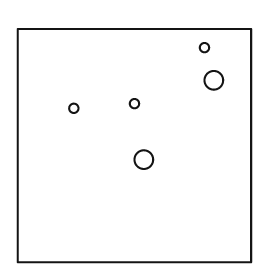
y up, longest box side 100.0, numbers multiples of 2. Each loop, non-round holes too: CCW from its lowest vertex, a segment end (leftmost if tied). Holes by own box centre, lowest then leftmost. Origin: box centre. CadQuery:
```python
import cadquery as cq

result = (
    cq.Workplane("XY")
    .moveTo(-50.0, -50.0)
    .lineTo(50.0, -50.0)
    .lineTo(50.0, 50.0)
    .lineTo(-50.0, 50.0)
    .close()
    .moveTo(4.0, -6.0)
    .circle(4.0)
    .moveTo(-26.0, 16.0)
    .circle(2.0)
    .moveTo(0.0, 18.0)
    .circle(2.0)
    .moveTo(34.0, 28.0)
    .circle(4.0)
    .moveTo(30.0, 42.0)
    .circle(2.0)
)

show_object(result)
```